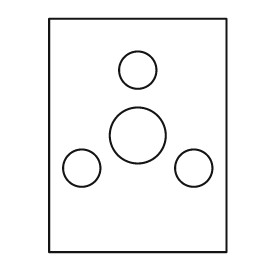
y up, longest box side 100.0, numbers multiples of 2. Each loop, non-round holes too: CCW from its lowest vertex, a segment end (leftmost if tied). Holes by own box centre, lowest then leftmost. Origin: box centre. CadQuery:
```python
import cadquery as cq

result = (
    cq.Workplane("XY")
    .moveTo(-38.0, -50.0)
    .lineTo(38.0, -50.0)
    .lineTo(38.0, 50.0)
    .lineTo(-38.0, 50.0)
    .close()
    .moveTo(-24.0, -14.0)
    .circle(8.0)
    .moveTo(24.0, -14.0)
    .circle(8.0)
    .moveTo(0.0, 0.0)
    .circle(12.0)
    .moveTo(0.0, 28.0)
    .circle(8.0)
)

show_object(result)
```